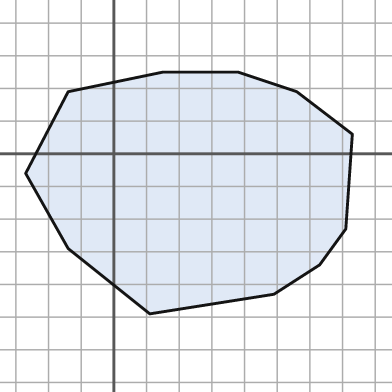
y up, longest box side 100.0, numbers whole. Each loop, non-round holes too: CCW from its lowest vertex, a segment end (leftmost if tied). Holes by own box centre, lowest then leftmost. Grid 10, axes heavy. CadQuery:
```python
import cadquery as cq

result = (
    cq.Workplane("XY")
    .moveTo(11.0, -49.0)
    .lineTo(49.0, -43.0)
    .lineTo(63.0, -34.0)
    .lineTo(71.0, -23.0)
    .lineTo(73.0, 6.0)
    .lineTo(56.0, 19.0)
    .lineTo(38.0, 25.0)
    .lineTo(15.0, 25.0)
    .lineTo(-14.0, 19.0)
    .lineTo(-27.0, -6.0)
    .lineTo(-14.0, -29.0)
    .close()
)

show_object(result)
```